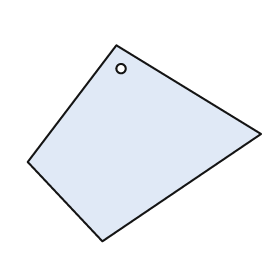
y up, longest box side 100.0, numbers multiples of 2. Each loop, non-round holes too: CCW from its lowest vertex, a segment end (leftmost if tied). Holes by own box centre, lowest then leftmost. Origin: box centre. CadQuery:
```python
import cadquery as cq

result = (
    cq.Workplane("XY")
    .moveTo(-18.0, -42.0)
    .lineTo(50.0, 4.0)
    .lineTo(-12.0, 42.0)
    .lineTo(-50.0, -8.0)
    .close()
    .moveTo(-10.0, 32.0)
    .circle(2.0)
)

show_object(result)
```